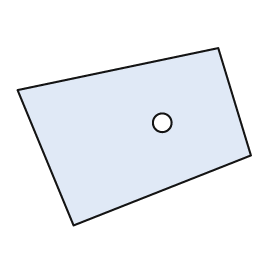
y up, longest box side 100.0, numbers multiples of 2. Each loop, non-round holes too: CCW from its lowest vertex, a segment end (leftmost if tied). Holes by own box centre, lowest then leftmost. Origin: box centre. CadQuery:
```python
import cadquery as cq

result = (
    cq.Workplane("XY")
    .moveTo(-26.0, -38.0)
    .lineTo(50.0, -8.0)
    .lineTo(36.0, 38.0)
    .lineTo(-50.0, 20.0)
    .close()
    .moveTo(12.0, 6.0)
    .circle(4.0)
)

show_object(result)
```